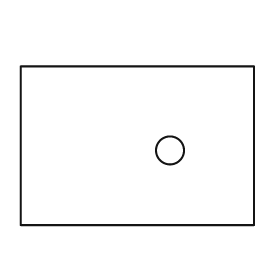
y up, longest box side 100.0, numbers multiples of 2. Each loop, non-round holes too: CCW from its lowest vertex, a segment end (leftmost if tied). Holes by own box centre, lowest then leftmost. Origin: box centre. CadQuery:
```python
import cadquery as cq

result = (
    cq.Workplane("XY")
    .moveTo(-50.0, -34.0)
    .lineTo(50.0, -34.0)
    .lineTo(50.0, 34.0)
    .lineTo(-50.0, 34.0)
    .close()
    .moveTo(14.0, -2.0)
    .circle(6.0)
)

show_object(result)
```